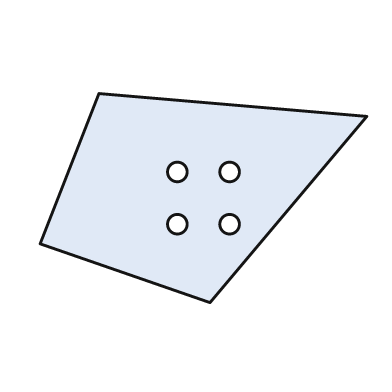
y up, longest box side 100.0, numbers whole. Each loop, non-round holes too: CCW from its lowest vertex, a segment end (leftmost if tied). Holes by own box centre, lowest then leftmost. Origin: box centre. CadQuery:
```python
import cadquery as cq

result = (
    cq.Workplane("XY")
    .moveTo(2.0, -32.0)
    .lineTo(50.0, 25.0)
    .lineTo(-32.0, 32.0)
    .lineTo(-50.0, -14.0)
    .close()
    .moveTo(-8.0, -8.0)
    .circle(3.0)
    .moveTo(8.0, -8.0)
    .circle(3.0)
    .moveTo(-8.0, 8.0)
    .circle(3.0)
    .moveTo(8.0, 8.0)
    .circle(3.0)
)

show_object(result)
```